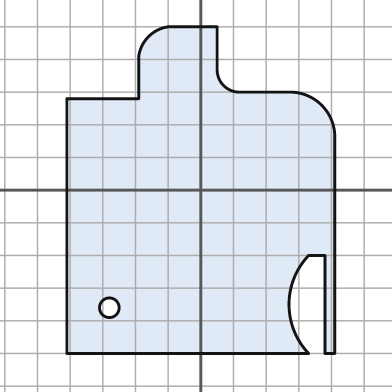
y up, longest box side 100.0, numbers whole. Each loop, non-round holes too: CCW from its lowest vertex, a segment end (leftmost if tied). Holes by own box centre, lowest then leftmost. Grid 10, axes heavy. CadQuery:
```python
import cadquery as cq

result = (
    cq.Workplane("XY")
    .moveTo(-41.0, -50.0)
    .lineTo(33.0, -50.0)
    .threePointArc((27.0, -35.0), (33.0, -20.0))
    .lineTo(38.0, -20.0)
    .lineTo(38.0, -50.0)
    .lineTo(41.0, -50.0)
    .lineTo(41.0, 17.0)
    .threePointArc((37.0, 26.0), (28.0, 30.0))
    .lineTo(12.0, 30.0)
    .threePointArc((7.0, 32.0), (5.0, 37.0))
    .lineTo(5.0, 50.0)
    .lineTo(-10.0, 50.0)
    .threePointArc((-16.0, 47.0), (-19.0, 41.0))
    .lineTo(-19.0, 28.0)
    .lineTo(-41.0, 28.0)
    .close()
    .moveTo(-28.0, -36.0)
    .circle(3.0)
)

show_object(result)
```